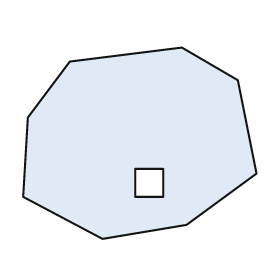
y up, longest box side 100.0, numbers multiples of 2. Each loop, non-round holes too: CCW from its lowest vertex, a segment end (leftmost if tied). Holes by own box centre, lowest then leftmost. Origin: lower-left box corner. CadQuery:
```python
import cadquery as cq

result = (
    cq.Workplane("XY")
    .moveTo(34.0, 0.0)
    .lineTo(70.0, 6.0)
    .lineTo(100.0, 28.0)
    .lineTo(92.0, 68.0)
    .lineTo(68.0, 82.0)
    .lineTo(20.0, 76.0)
    .lineTo(2.0, 52.0)
    .lineTo(0.0, 18.0)
    .close()
    .moveTo(48.0, 18.0)
    .lineTo(60.0, 18.0)
    .lineTo(60.0, 30.0)
    .lineTo(48.0, 30.0)
    .close()
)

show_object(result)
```